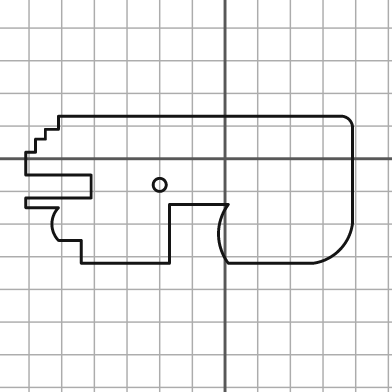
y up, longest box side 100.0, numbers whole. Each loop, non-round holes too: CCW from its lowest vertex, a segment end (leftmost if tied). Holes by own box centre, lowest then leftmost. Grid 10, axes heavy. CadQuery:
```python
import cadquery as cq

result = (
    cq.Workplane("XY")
    .moveTo(-44.0, -32.0)
    .lineTo(-17.0, -32.0)
    .lineTo(-17.0, -14.0)
    .lineTo(1.0, -14.0)
    .threePointArc((-2.0, -23.0), (1.0, -32.0))
    .lineTo(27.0, -32.0)
    .threePointArc((35.0, -28.0), (39.0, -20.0))
    .lineTo(39.0, 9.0)
    .threePointArc((38.0, 12.0), (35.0, 13.0))
    .lineTo(-51.0, 13.0)
    .lineTo(-51.0, 9.0)
    .lineTo(-55.0, 9.0)
    .lineTo(-55.0, 6.0)
    .lineTo(-58.0, 6.0)
    .lineTo(-58.0, 2.0)
    .lineTo(-61.0, 2.0)
    .lineTo(-61.0, -5.0)
    .lineTo(-41.0, -5.0)
    .lineTo(-41.0, -12.0)
    .lineTo(-61.0, -12.0)
    .lineTo(-61.0, -15.0)
    .lineTo(-51.0, -15.0)
    .threePointArc((-53.0, -20.0), (-51.0, -25.0))
    .lineTo(-44.0, -25.0)
    .close()
    .moveTo(-20.0, -8.0)
    .circle(2.0)
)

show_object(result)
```